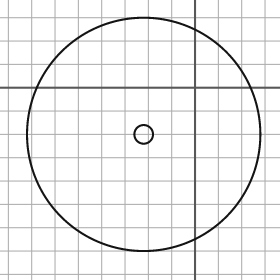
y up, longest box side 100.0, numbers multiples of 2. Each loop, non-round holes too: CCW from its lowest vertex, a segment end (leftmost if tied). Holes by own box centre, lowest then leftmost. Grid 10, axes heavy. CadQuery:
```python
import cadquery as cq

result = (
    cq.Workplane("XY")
    .moveTo(-22.0, -20.0)
    .circle(50.0)
    .moveTo(-22.0, -20.0)
    .circle(4.0)
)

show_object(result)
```